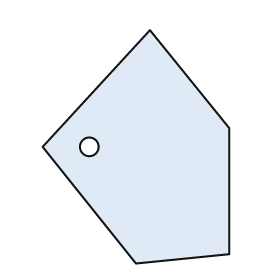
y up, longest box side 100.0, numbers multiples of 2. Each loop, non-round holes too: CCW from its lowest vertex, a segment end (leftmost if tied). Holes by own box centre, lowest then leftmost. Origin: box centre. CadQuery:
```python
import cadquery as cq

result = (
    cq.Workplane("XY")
    .moveTo(0.0, -50.0)
    .lineTo(40.0, -46.0)
    .lineTo(40.0, 8.0)
    .lineTo(6.0, 50.0)
    .lineTo(-40.0, 0.0)
    .close()
    .moveTo(-20.0, 0.0)
    .circle(4.0)
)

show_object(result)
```